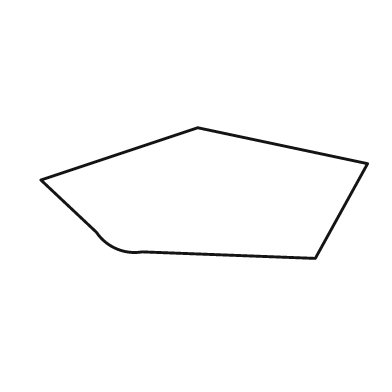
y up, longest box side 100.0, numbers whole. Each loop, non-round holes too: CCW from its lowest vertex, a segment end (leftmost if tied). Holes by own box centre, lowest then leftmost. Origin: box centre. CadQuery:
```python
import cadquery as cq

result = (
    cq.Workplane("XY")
    .moveTo(34.0, -20.0)
    .lineTo(50.0, 9.0)
    .lineTo(-2.0, 20.0)
    .lineTo(-50.0, 4.0)
    .lineTo(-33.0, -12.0)
    .threePointArc((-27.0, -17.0), (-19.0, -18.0))
    .close()
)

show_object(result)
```